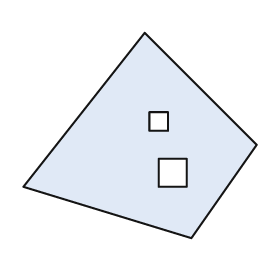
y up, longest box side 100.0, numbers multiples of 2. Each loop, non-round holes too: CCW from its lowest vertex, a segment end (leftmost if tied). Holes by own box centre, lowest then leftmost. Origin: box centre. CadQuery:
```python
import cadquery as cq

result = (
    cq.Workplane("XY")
    .moveTo(22.0, -44.0)
    .lineTo(50.0, -4.0)
    .lineTo(2.0, 44.0)
    .lineTo(-50.0, -22.0)
    .close()
    .moveTo(8.0, -22.0)
    .lineTo(20.0, -22.0)
    .lineTo(20.0, -10.0)
    .lineTo(8.0, -10.0)
    .close()
    .moveTo(4.0, 2.0)
    .lineTo(12.0, 2.0)
    .lineTo(12.0, 10.0)
    .lineTo(4.0, 10.0)
    .close()
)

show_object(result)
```